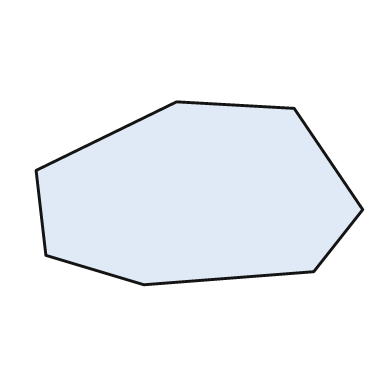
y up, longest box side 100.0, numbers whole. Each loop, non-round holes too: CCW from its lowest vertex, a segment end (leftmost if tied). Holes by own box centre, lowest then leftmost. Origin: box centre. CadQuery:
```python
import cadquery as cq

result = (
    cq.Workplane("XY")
    .moveTo(-17.0, -28.0)
    .lineTo(35.0, -24.0)
    .lineTo(50.0, -5.0)
    .lineTo(29.0, 26.0)
    .lineTo(-7.0, 28.0)
    .lineTo(-50.0, 7.0)
    .lineTo(-47.0, -19.0)
    .close()
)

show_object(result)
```